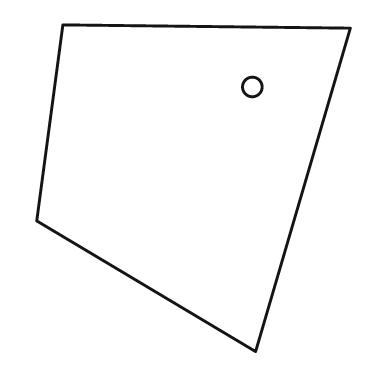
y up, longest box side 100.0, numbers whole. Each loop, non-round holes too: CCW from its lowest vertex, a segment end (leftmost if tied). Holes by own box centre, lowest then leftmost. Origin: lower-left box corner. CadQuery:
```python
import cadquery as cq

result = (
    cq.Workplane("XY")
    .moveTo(67.0, 0.0)
    .lineTo(96.0, 99.0)
    .lineTo(8.0, 100.0)
    .lineTo(0.0, 40.0)
    .close()
    .moveTo(66.0, 81.0)
    .circle(3.0)
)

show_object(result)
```